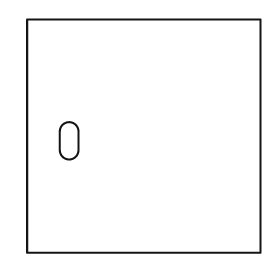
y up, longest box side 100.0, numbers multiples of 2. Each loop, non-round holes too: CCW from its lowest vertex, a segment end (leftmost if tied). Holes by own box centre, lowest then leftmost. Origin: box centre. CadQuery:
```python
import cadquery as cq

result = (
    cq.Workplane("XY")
    .moveTo(-50.0, -50.0)
    .lineTo(50.0, -50.0)
    .lineTo(50.0, 50.0)
    .lineTo(-50.0, 50.0)
    .close()
    .moveTo(-36.0, -6.0)
    .threePointArc((-32.0, -10.0), (-28.0, -6.0))
    .lineTo(-28.0, 2.0)
    .threePointArc((-32.0, 6.0), (-36.0, 2.0))
    .close()
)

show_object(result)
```